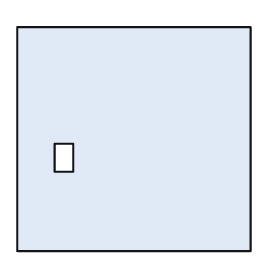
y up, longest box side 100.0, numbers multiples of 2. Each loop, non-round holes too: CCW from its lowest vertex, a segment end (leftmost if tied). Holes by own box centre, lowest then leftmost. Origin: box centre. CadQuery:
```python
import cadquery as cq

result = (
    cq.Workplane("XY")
    .moveTo(-50.0, -48.0)
    .lineTo(50.0, -48.0)
    .lineTo(50.0, 48.0)
    .lineTo(-50.0, 48.0)
    .close()
    .moveTo(-34.0, -14.0)
    .lineTo(-26.0, -14.0)
    .lineTo(-26.0, -2.0)
    .lineTo(-34.0, -2.0)
    .close()
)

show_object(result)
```